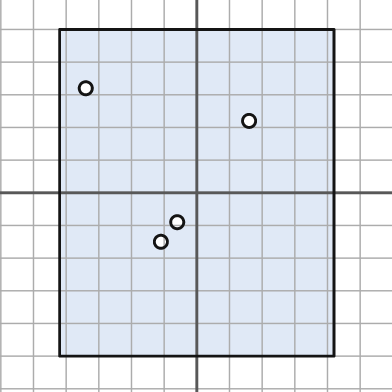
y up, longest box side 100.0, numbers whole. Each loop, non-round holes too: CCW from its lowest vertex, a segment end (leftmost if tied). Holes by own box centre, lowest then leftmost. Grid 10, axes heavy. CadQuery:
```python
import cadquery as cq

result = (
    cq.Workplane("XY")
    .moveTo(-42.0, -50.0)
    .lineTo(42.0, -50.0)
    .lineTo(42.0, 50.0)
    .lineTo(-42.0, 50.0)
    .close()
    .moveTo(-11.0, -15.0)
    .circle(2.0)
    .moveTo(-6.0, -9.0)
    .circle(2.0)
    .moveTo(16.0, 22.0)
    .circle(2.0)
    .moveTo(-34.0, 32.0)
    .circle(2.0)
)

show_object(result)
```